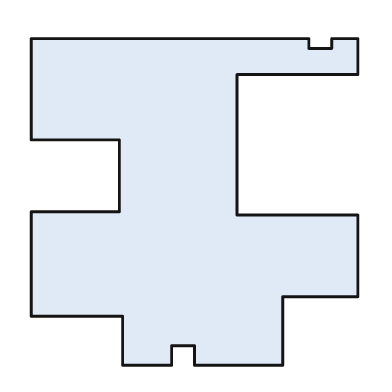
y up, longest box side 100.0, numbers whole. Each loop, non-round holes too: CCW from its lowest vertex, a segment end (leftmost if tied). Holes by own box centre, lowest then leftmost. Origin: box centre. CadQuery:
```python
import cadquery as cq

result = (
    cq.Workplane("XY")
    .moveTo(-22.0, -50.0)
    .lineTo(-7.0, -50.0)
    .lineTo(-7.0, -44.0)
    .lineTo(0.0, -44.0)
    .lineTo(0.0, -50.0)
    .lineTo(27.0, -50.0)
    .lineTo(27.0, -29.0)
    .lineTo(50.0, -29.0)
    .lineTo(50.0, -4.0)
    .lineTo(13.0, -4.0)
    .lineTo(13.0, 39.0)
    .lineTo(50.0, 39.0)
    .lineTo(50.0, 50.0)
    .lineTo(42.0, 50.0)
    .lineTo(42.0, 47.0)
    .lineTo(35.0, 47.0)
    .lineTo(35.0, 50.0)
    .lineTo(-50.0, 50.0)
    .lineTo(-50.0, 19.0)
    .lineTo(-23.0, 19.0)
    .lineTo(-23.0, -3.0)
    .lineTo(-50.0, -3.0)
    .lineTo(-50.0, -35.0)
    .lineTo(-22.0, -35.0)
    .close()
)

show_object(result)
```